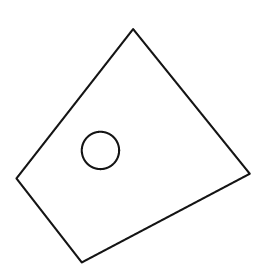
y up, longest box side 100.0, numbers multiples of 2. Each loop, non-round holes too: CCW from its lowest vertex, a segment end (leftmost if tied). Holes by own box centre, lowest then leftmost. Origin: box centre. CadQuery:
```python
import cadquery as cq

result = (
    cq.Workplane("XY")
    .moveTo(-22.0, -50.0)
    .lineTo(50.0, -12.0)
    .lineTo(0.0, 50.0)
    .lineTo(-50.0, -14.0)
    .close()
    .moveTo(-14.0, -2.0)
    .circle(8.0)
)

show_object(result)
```